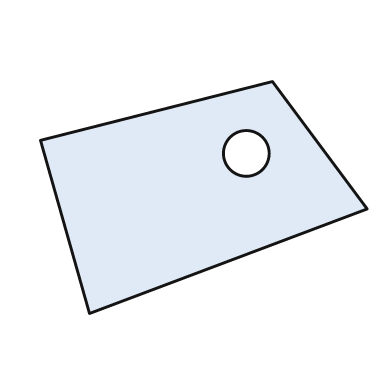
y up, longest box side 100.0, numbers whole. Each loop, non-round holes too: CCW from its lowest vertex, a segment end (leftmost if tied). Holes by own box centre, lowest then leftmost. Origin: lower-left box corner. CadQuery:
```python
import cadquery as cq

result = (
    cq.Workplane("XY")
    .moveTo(15.0, 0.0)
    .lineTo(100.0, 32.0)
    .lineTo(71.0, 71.0)
    .lineTo(0.0, 53.0)
    .close()
    .moveTo(63.0, 49.0)
    .circle(7.0)
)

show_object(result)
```